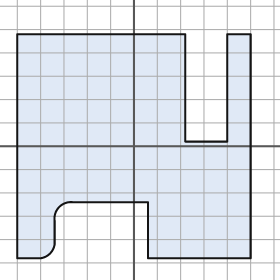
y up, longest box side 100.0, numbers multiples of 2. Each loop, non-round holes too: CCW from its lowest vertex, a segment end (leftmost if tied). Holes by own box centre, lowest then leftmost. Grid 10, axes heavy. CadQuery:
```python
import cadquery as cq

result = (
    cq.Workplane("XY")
    .moveTo(-50.0, -48.0)
    .lineTo(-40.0, -48.0)
    .threePointArc((-36.0, -46.0), (-34.0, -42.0))
    .lineTo(-34.0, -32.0)
    .threePointArc((-32.0, -26.0), (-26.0, -24.0))
    .lineTo(6.0, -24.0)
    .lineTo(6.0, -48.0)
    .lineTo(50.0, -48.0)
    .lineTo(50.0, 48.0)
    .lineTo(40.0, 48.0)
    .lineTo(40.0, 2.0)
    .lineTo(22.0, 2.0)
    .lineTo(22.0, 48.0)
    .lineTo(-50.0, 48.0)
    .close()
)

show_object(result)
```